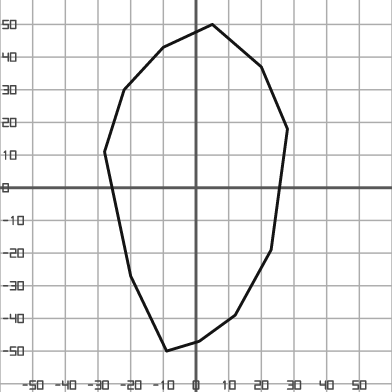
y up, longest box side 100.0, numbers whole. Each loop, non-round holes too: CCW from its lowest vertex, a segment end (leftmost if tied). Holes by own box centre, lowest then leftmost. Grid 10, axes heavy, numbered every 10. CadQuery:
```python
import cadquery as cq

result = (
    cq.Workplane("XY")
    .moveTo(-9.0, -50.0)
    .lineTo(1.0, -47.0)
    .lineTo(12.0, -39.0)
    .lineTo(23.0, -19.0)
    .lineTo(28.0, 18.0)
    .lineTo(20.0, 37.0)
    .lineTo(5.0, 50.0)
    .lineTo(-10.0, 43.0)
    .lineTo(-22.0, 30.0)
    .lineTo(-28.0, 11.0)
    .lineTo(-20.0, -27.0)
    .close()
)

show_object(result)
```